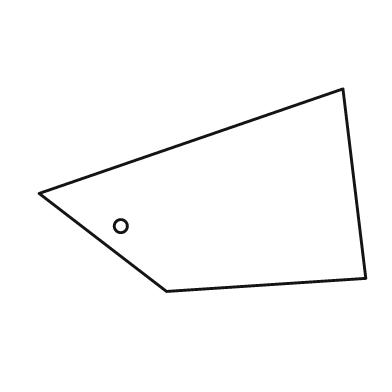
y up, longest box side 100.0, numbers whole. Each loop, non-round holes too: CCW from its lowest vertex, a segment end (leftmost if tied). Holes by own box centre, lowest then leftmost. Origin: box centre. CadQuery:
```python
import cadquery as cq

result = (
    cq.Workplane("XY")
    .moveTo(-11.0, -31.0)
    .lineTo(50.0, -27.0)
    .lineTo(43.0, 31.0)
    .lineTo(-50.0, -1.0)
    .close()
    .moveTo(-25.0, -11.0)
    .circle(2.0)
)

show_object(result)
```